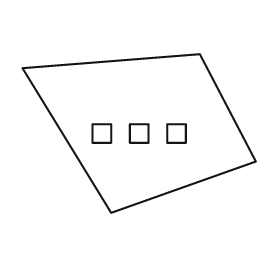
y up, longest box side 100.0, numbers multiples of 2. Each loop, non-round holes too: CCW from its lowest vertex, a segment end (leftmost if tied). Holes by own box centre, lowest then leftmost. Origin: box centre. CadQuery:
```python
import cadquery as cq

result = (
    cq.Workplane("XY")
    .moveTo(-12.0, -34.0)
    .lineTo(50.0, -12.0)
    .lineTo(26.0, 34.0)
    .lineTo(-50.0, 28.0)
    .close()
    .moveTo(-20.0, -4.0)
    .lineTo(-12.0, -4.0)
    .lineTo(-12.0, 4.0)
    .lineTo(-20.0, 4.0)
    .close()
    .moveTo(-4.0, -4.0)
    .lineTo(4.0, -4.0)
    .lineTo(4.0, 4.0)
    .lineTo(-4.0, 4.0)
    .close()
    .moveTo(12.0, -4.0)
    .lineTo(20.0, -4.0)
    .lineTo(20.0, 4.0)
    .lineTo(12.0, 4.0)
    .close()
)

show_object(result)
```